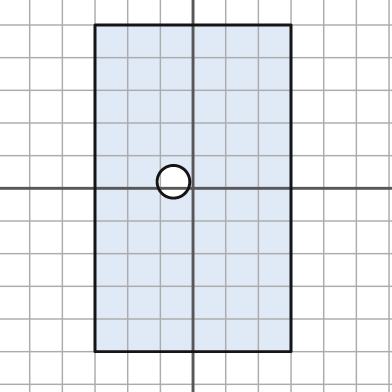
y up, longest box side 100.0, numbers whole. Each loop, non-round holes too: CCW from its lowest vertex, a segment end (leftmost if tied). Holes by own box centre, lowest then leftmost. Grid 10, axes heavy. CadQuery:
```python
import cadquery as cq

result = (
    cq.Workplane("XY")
    .moveTo(-30.0, -50.0)
    .lineTo(30.0, -50.0)
    .lineTo(30.0, 50.0)
    .lineTo(-30.0, 50.0)
    .close()
    .moveTo(-6.0, 2.0)
    .circle(5.0)
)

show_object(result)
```